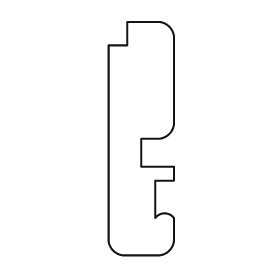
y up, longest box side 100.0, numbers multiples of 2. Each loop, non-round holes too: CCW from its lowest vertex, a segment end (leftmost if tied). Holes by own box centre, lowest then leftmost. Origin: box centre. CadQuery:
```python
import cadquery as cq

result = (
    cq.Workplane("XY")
    .moveTo(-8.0, -50.0)
    .lineTo(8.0, -50.0)
    .threePointArc((12.0, -48.0), (14.0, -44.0))
    .lineTo(14.0, -34.0)
    .threePointArc((10.0, -32.0), (6.0, -34.0))
    .lineTo(6.0, -18.0)
    .lineTo(14.0, -18.0)
    .lineTo(14.0, -12.0)
    .lineTo(0.0, -12.0)
    .lineTo(0.0, 0.0)
    .lineTo(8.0, 0.0)
    .threePointArc((12.0, 2.0), (14.0, 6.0))
    .lineTo(14.0, 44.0)
    .threePointArc((12.0, 48.0), (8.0, 50.0))
    .lineTo(-6.0, 50.0)
    .lineTo(-6.0, 40.0)
    .lineTo(-14.0, 40.0)
    .lineTo(-14.0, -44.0)
    .threePointArc((-12.0, -48.0), (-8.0, -50.0))
    .close()
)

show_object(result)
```